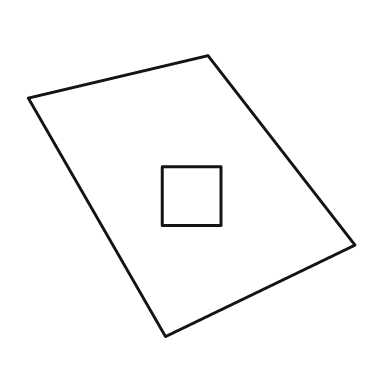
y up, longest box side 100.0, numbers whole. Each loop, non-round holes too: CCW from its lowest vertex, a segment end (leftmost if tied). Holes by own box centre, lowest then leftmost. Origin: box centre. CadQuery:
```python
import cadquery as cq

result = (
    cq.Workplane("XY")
    .moveTo(-8.0, -43.0)
    .lineTo(50.0, -15.0)
    .lineTo(5.0, 43.0)
    .lineTo(-50.0, 30.0)
    .close()
    .moveTo(-9.0, -9.0)
    .lineTo(9.0, -9.0)
    .lineTo(9.0, 9.0)
    .lineTo(-9.0, 9.0)
    .close()
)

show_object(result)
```